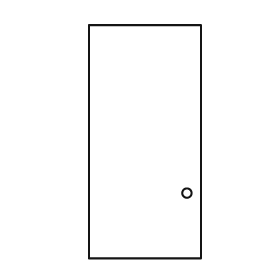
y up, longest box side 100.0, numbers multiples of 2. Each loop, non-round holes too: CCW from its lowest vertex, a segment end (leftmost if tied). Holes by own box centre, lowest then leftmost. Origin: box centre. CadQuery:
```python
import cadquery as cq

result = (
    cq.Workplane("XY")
    .moveTo(-24.0, -50.0)
    .lineTo(24.0, -50.0)
    .lineTo(24.0, 50.0)
    .lineTo(-24.0, 50.0)
    .close()
    .moveTo(18.0, -22.0)
    .circle(2.0)
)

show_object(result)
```